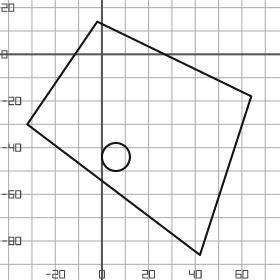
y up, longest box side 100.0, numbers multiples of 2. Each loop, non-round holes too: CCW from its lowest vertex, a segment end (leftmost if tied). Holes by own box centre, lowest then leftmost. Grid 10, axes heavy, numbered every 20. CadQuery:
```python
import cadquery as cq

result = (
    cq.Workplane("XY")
    .moveTo(42.0, -86.0)
    .lineTo(64.0, -18.0)
    .lineTo(-2.0, 14.0)
    .lineTo(-32.0, -30.0)
    .close()
    .moveTo(6.0, -44.0)
    .circle(6.0)
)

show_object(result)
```